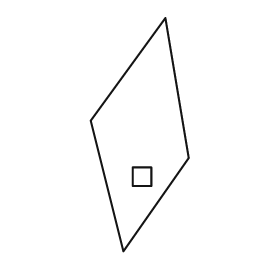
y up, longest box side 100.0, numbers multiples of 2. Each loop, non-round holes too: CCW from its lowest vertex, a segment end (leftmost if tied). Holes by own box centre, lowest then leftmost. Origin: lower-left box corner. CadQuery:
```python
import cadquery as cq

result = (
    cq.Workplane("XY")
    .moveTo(14.0, 0.0)
    .lineTo(42.0, 40.0)
    .lineTo(32.0, 100.0)
    .lineTo(0.0, 56.0)
    .close()
    .moveTo(18.0, 28.0)
    .lineTo(26.0, 28.0)
    .lineTo(26.0, 36.0)
    .lineTo(18.0, 36.0)
    .close()
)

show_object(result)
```